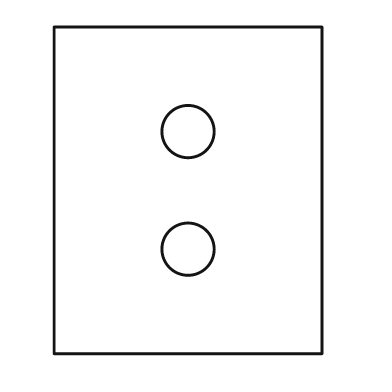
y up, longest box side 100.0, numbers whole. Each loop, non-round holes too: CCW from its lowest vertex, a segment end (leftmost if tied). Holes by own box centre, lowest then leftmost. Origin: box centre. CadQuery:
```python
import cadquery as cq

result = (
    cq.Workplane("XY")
    .moveTo(-41.0, -50.0)
    .lineTo(41.0, -50.0)
    .lineTo(41.0, 50.0)
    .lineTo(-41.0, 50.0)
    .close()
    .moveTo(0.0, -18.0)
    .circle(8.0)
    .moveTo(0.0, 18.0)
    .circle(8.0)
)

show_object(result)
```